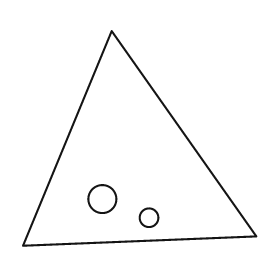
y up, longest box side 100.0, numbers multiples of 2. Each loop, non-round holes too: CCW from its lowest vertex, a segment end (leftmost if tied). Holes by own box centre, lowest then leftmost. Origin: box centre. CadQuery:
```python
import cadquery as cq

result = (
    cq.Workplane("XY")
    .moveTo(-50.0, -46.0)
    .lineTo(50.0, -42.0)
    .lineTo(-12.0, 46.0)
    .close()
    .moveTo(4.0, -34.0)
    .circle(4.0)
    .moveTo(-16.0, -26.0)
    .circle(6.0)
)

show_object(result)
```